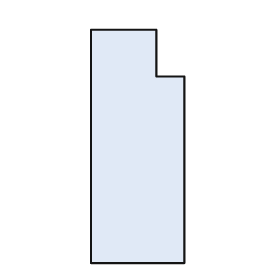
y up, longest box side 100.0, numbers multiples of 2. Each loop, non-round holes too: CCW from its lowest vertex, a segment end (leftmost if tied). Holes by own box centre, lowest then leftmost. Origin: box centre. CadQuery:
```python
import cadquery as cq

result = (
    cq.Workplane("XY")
    .moveTo(-20.0, -50.0)
    .lineTo(20.0, -50.0)
    .lineTo(20.0, 30.0)
    .lineTo(8.0, 30.0)
    .lineTo(8.0, 50.0)
    .lineTo(-20.0, 50.0)
    .close()
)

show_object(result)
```